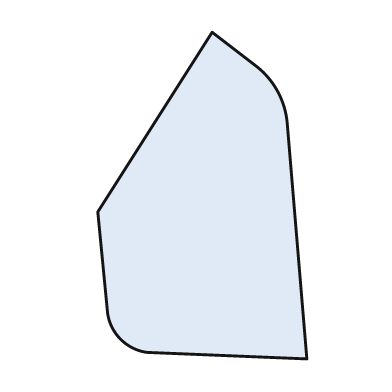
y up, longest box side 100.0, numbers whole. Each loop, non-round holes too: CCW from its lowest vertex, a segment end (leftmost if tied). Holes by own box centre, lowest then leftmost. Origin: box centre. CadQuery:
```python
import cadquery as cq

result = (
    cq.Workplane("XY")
    .moveTo(32.0, -50.0)
    .lineTo(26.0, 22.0)
    .threePointArc((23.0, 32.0), (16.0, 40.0))
    .lineTo(3.0, 50.0)
    .lineTo(-32.0, -5.0)
    .lineTo(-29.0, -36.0)
    .threePointArc((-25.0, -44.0), (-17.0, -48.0))
    .close()
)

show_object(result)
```